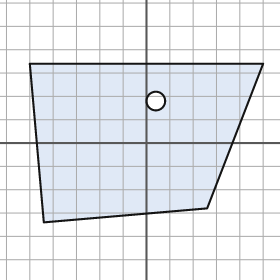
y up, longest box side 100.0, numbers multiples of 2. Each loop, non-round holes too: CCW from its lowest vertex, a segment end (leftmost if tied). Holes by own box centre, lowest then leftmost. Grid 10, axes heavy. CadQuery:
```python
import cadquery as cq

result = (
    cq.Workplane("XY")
    .moveTo(-44.0, -34.0)
    .lineTo(26.0, -28.0)
    .lineTo(50.0, 34.0)
    .lineTo(-50.0, 34.0)
    .close()
    .moveTo(4.0, 18.0)
    .circle(4.0)
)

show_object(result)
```